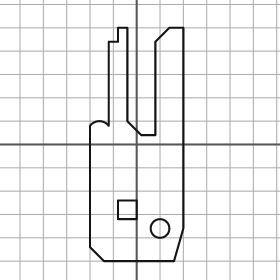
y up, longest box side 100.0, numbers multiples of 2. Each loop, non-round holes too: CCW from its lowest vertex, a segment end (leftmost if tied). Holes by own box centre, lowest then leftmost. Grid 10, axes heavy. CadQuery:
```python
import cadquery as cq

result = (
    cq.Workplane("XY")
    .moveTo(-14.0, -50.0)
    .lineTo(16.0, -50.0)
    .lineTo(20.0, -36.0)
    .lineTo(20.0, 50.0)
    .lineTo(14.0, 50.0)
    .lineTo(8.0, 44.0)
    .lineTo(8.0, 4.0)
    .lineTo(2.0, 4.0)
    .lineTo(-4.0, 10.0)
    .lineTo(-4.0, 50.0)
    .lineTo(-8.0, 50.0)
    .lineTo(-8.0, 44.0)
    .lineTo(-12.0, 44.0)
    .lineTo(-12.0, 8.0)
    .threePointArc((-16.0, 10.0), (-20.0, 8.0))
    .lineTo(-20.0, -44.0)
    .close()
    .moveTo(10.0, -36.0)
    .circle(4.0)
    .moveTo(-8.0, -32.0)
    .lineTo(0.0, -32.0)
    .lineTo(0.0, -24.0)
    .lineTo(-8.0, -24.0)
    .close()
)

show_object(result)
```